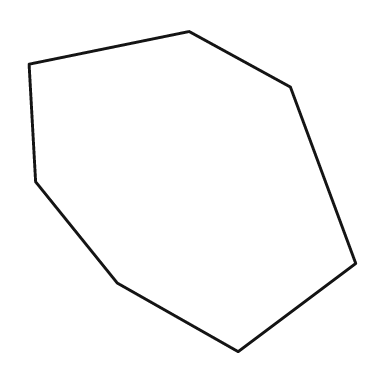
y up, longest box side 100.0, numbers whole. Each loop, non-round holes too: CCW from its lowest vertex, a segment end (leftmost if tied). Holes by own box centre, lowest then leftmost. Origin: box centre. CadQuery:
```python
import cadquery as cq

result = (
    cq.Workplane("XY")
    .moveTo(14.0, -49.0)
    .lineTo(50.0, -22.0)
    .lineTo(30.0, 32.0)
    .lineTo(-1.0, 49.0)
    .lineTo(-50.0, 39.0)
    .lineTo(-48.0, 3.0)
    .lineTo(-23.0, -28.0)
    .close()
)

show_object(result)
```